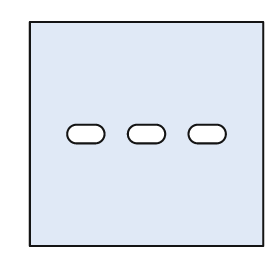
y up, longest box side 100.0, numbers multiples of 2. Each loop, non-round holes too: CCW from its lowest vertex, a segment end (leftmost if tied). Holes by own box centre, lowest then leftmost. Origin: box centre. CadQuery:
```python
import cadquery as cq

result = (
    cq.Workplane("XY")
    .moveTo(-50.0, -48.0)
    .lineTo(50.0, -48.0)
    .lineTo(50.0, 48.0)
    .lineTo(-50.0, 48.0)
    .close()
    .moveTo(-30.0, -4.0)
    .lineTo(-22.0, -4.0)
    .threePointArc((-18.0, 0.0), (-22.0, 4.0))
    .lineTo(-30.0, 4.0)
    .threePointArc((-34.0, 0.0), (-30.0, -4.0))
    .close()
    .moveTo(-4.0, -4.0)
    .lineTo(4.0, -4.0)
    .threePointArc((8.0, 0.0), (4.0, 4.0))
    .lineTo(-4.0, 4.0)
    .threePointArc((-8.0, 0.0), (-4.0, -4.0))
    .close()
    .moveTo(22.0, -4.0)
    .lineTo(30.0, -4.0)
    .threePointArc((34.0, 0.0), (30.0, 4.0))
    .lineTo(22.0, 4.0)
    .threePointArc((18.0, 0.0), (22.0, -4.0))
    .close()
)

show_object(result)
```